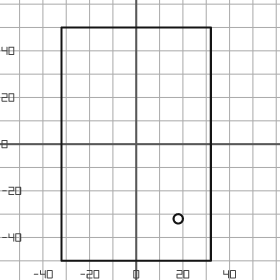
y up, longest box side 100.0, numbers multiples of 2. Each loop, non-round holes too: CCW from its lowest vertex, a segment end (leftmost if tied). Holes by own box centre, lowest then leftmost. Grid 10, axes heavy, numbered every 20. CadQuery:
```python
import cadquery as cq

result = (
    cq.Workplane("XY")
    .moveTo(-32.0, -50.0)
    .lineTo(32.0, -50.0)
    .lineTo(32.0, 50.0)
    .lineTo(-32.0, 50.0)
    .close()
    .moveTo(18.0, -32.0)
    .circle(2.0)
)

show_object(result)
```